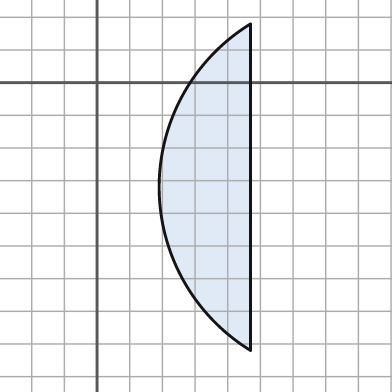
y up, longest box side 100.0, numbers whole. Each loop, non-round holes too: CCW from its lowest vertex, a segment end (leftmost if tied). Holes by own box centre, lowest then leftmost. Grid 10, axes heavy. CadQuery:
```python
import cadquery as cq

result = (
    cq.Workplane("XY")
    .moveTo(47.0, -82.0)
    .lineTo(47.0, 18.0)
    .threePointArc((19.0, -32.0), (47.0, -82.0))
    .close()
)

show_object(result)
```